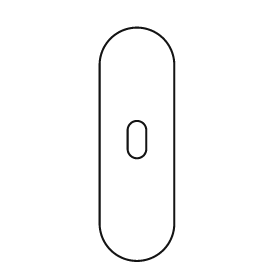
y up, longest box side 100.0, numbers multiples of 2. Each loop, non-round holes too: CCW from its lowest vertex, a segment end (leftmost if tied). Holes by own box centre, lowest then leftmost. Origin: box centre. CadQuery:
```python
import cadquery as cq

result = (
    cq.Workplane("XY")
    .moveTo(-16.0, -34.0)
    .threePointArc((0.0, -50.0), (16.0, -34.0))
    .lineTo(16.0, 34.0)
    .threePointArc((0.0, 50.0), (-16.0, 34.0))
    .close()
    .moveTo(-4.0, -2.0)
    .threePointArc((0.0, -6.0), (4.0, -2.0))
    .lineTo(4.0, 6.0)
    .threePointArc((0.0, 10.0), (-4.0, 6.0))
    .close()
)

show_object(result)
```